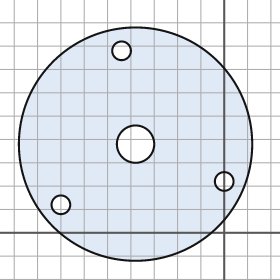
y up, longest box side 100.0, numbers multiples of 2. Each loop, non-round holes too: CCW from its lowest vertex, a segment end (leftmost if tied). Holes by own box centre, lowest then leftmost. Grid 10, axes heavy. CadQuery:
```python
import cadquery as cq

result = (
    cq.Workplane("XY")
    .moveTo(-38.0, 38.0)
    .circle(50.0)
    .moveTo(-70.0, 12.0)
    .circle(4.0)
    .moveTo(0.0, 22.0)
    .circle(4.0)
    .moveTo(-38.0, 38.0)
    .circle(8.0)
    .moveTo(-44.0, 78.0)
    .circle(4.0)
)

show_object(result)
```